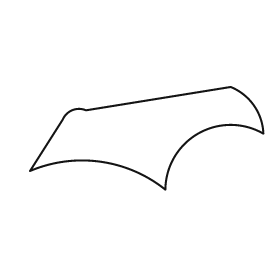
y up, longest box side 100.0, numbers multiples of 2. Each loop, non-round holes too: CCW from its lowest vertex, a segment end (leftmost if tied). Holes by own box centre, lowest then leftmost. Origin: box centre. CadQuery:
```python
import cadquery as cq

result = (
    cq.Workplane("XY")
    .moveTo(8.0, -22.0)
    .threePointArc((22.0, 2.0), (50.0, 2.0))
    .threePointArc((46.0, 14.0), (36.0, 22.0))
    .lineTo(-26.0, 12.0)
    .threePointArc((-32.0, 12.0), (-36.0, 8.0))
    .lineTo(-50.0, -14.0)
    .threePointArc((-20.0, -10.0), (8.0, -22.0))
    .close()
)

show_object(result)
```